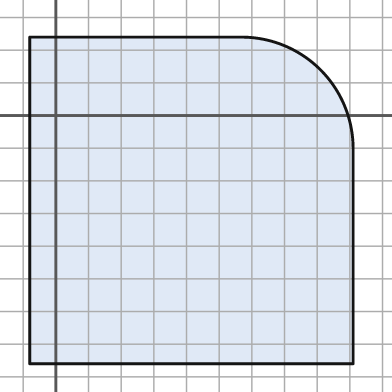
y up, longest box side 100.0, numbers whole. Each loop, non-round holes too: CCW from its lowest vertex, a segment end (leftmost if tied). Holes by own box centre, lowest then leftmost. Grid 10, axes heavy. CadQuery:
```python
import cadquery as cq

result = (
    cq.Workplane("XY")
    .moveTo(-8.0, -76.0)
    .lineTo(91.0, -76.0)
    .lineTo(91.0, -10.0)
    .threePointArc((81.0, 14.0), (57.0, 24.0))
    .lineTo(-8.0, 24.0)
    .close()
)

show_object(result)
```